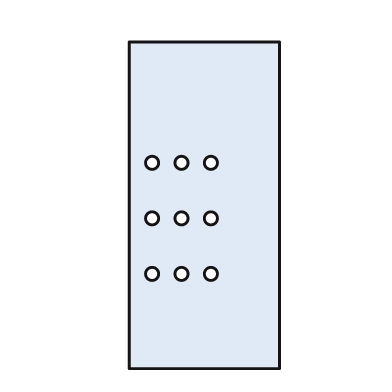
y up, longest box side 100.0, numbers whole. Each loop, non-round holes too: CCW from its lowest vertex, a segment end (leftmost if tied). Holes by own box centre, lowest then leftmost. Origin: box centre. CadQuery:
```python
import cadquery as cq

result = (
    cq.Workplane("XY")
    .moveTo(-23.0, -50.0)
    .lineTo(23.0, -50.0)
    .lineTo(23.0, 50.0)
    .lineTo(-23.0, 50.0)
    .close()
    .moveTo(-16.0, -21.0)
    .circle(2.0)
    .moveTo(-7.0, -21.0)
    .circle(2.0)
    .moveTo(2.0, -21.0)
    .circle(2.0)
    .moveTo(-16.0, -4.0)
    .circle(2.0)
    .moveTo(-7.0, -4.0)
    .circle(2.0)
    .moveTo(2.0, -4.0)
    .circle(2.0)
    .moveTo(-16.0, 13.0)
    .circle(2.0)
    .moveTo(-7.0, 13.0)
    .circle(2.0)
    .moveTo(2.0, 13.0)
    .circle(2.0)
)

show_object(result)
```